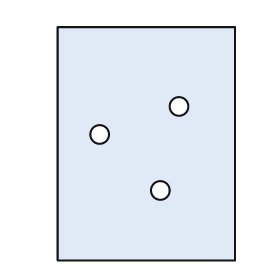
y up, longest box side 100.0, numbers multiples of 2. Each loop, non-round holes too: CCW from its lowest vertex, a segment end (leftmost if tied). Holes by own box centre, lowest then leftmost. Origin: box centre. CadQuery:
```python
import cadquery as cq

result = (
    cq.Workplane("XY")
    .moveTo(-38.0, -50.0)
    .lineTo(38.0, -50.0)
    .lineTo(38.0, 50.0)
    .lineTo(-38.0, 50.0)
    .close()
    .moveTo(6.0, -20.0)
    .circle(4.0)
    .moveTo(-20.0, 4.0)
    .circle(4.0)
    .moveTo(14.0, 16.0)
    .circle(4.0)
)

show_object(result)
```